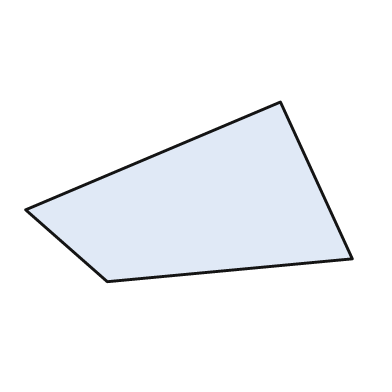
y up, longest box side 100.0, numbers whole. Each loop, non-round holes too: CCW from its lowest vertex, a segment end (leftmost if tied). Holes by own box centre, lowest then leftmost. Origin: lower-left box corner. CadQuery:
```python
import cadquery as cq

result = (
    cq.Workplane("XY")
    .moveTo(25.0, 0.0)
    .lineTo(100.0, 7.0)
    .lineTo(78.0, 55.0)
    .lineTo(0.0, 22.0)
    .close()
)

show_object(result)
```